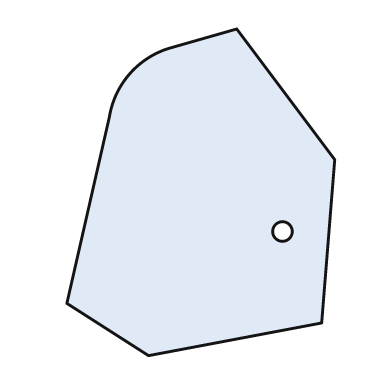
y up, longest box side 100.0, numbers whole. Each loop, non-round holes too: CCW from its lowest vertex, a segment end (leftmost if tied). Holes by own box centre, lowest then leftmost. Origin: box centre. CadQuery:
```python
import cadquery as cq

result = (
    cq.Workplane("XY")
    .moveTo(-16.0, -50.0)
    .lineTo(37.0, -40.0)
    .lineTo(41.0, 10.0)
    .lineTo(11.0, 50.0)
    .lineTo(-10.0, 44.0)
    .threePointArc((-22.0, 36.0), (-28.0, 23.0))
    .lineTo(-41.0, -34.0)
    .close()
    .moveTo(25.0, -12.0)
    .circle(3.0)
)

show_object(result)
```